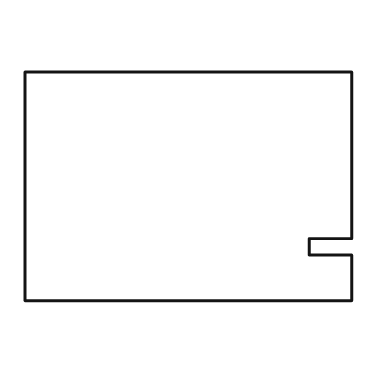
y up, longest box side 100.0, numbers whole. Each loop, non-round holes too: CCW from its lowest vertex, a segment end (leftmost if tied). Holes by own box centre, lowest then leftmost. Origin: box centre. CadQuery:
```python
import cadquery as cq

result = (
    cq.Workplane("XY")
    .moveTo(-50.0, -35.0)
    .lineTo(50.0, -35.0)
    .lineTo(50.0, -21.0)
    .lineTo(37.0, -21.0)
    .lineTo(37.0, -16.0)
    .lineTo(50.0, -16.0)
    .lineTo(50.0, 35.0)
    .lineTo(-50.0, 35.0)
    .close()
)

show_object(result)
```